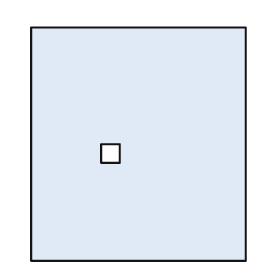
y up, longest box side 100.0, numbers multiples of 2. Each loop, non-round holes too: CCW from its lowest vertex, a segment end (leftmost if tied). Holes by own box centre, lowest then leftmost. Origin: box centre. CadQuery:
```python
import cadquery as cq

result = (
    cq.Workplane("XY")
    .moveTo(-46.0, -50.0)
    .lineTo(46.0, -50.0)
    .lineTo(46.0, 50.0)
    .lineTo(-46.0, 50.0)
    .close()
    .moveTo(-16.0, -8.0)
    .lineTo(-8.0, -8.0)
    .lineTo(-8.0, 0.0)
    .lineTo(-16.0, 0.0)
    .close()
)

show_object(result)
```